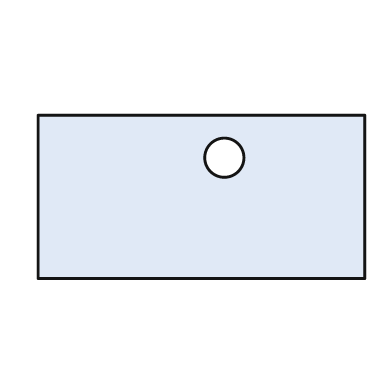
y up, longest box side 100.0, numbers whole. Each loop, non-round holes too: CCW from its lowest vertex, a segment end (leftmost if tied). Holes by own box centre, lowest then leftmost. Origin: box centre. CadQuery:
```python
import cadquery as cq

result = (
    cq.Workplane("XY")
    .moveTo(-50.0, -25.0)
    .lineTo(50.0, -25.0)
    .lineTo(50.0, 25.0)
    .lineTo(-50.0, 25.0)
    .close()
    .moveTo(7.0, 12.0)
    .circle(6.0)
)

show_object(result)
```